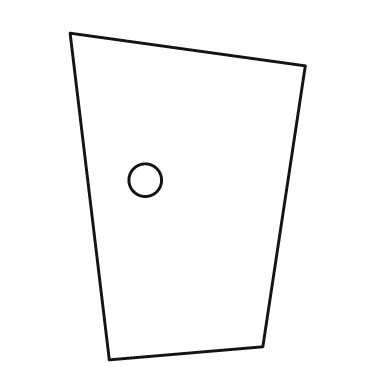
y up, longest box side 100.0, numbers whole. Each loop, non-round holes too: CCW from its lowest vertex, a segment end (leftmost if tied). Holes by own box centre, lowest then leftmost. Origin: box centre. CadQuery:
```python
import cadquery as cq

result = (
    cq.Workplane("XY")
    .moveTo(-24.0, -50.0)
    .lineTo(23.0, -46.0)
    .lineTo(36.0, 40.0)
    .lineTo(-36.0, 50.0)
    .close()
    .moveTo(-13.0, 5.0)
    .circle(5.0)
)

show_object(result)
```